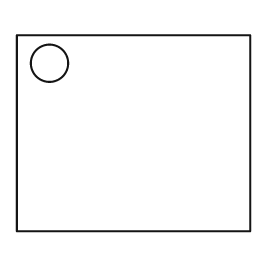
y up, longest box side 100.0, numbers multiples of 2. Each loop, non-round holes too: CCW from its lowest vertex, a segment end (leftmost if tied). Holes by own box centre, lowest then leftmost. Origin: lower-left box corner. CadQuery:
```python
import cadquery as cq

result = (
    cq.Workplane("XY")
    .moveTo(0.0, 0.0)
    .lineTo(100.0, 0.0)
    .lineTo(100.0, 84.0)
    .lineTo(0.0, 84.0)
    .close()
    .moveTo(14.0, 72.0)
    .circle(8.0)
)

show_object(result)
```